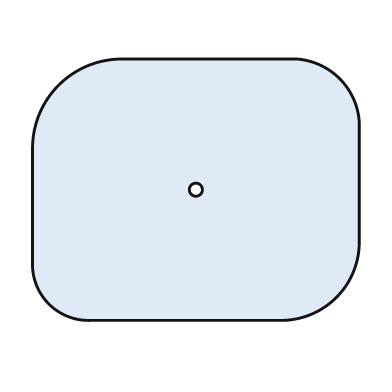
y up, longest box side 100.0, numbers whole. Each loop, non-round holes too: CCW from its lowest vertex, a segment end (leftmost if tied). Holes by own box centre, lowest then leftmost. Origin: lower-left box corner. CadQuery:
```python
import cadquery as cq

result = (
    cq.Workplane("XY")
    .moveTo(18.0, 0.0)
    .lineTo(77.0, 0.0)
    .threePointArc((93.0, 7.0), (100.0, 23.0))
    .lineTo(100.0, 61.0)
    .threePointArc((94.0, 74.0), (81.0, 80.0))
    .lineTo(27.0, 80.0)
    .threePointArc((8.0, 72.0), (0.0, 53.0))
    .lineTo(0.0, 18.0)
    .threePointArc((5.0, 5.0), (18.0, 0.0))
    .close()
    .moveTo(50.0, 40.0)
    .circle(2.0)
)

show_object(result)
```